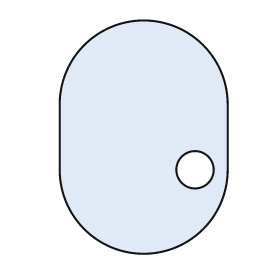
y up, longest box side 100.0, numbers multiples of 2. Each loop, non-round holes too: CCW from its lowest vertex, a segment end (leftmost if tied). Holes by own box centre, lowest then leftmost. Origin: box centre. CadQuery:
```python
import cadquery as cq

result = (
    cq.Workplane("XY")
    .moveTo(-36.0, -14.0)
    .threePointArc((0.0, -50.0), (36.0, -14.0))
    .lineTo(36.0, 14.0)
    .threePointArc((0.0, 50.0), (-36.0, 14.0))
    .close()
    .moveTo(22.0, -14.0)
    .circle(8.0)
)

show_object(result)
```